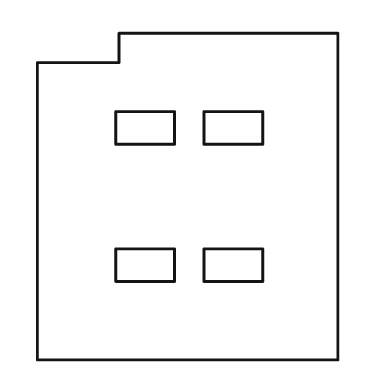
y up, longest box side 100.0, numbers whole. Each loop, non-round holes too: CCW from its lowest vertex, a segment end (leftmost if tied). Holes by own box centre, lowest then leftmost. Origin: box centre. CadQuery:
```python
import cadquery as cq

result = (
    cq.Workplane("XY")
    .moveTo(-46.0, -50.0)
    .lineTo(46.0, -50.0)
    .lineTo(46.0, 50.0)
    .lineTo(-21.0, 50.0)
    .lineTo(-21.0, 41.0)
    .lineTo(-46.0, 41.0)
    .close()
    .moveTo(-22.0, -26.0)
    .lineTo(-4.0, -26.0)
    .lineTo(-4.0, -16.0)
    .lineTo(-22.0, -16.0)
    .close()
    .moveTo(5.0, -26.0)
    .lineTo(23.0, -26.0)
    .lineTo(23.0, -16.0)
    .lineTo(5.0, -16.0)
    .close()
    .moveTo(-22.0, 16.0)
    .lineTo(-4.0, 16.0)
    .lineTo(-4.0, 26.0)
    .lineTo(-22.0, 26.0)
    .close()
    .moveTo(5.0, 16.0)
    .lineTo(23.0, 16.0)
    .lineTo(23.0, 26.0)
    .lineTo(5.0, 26.0)
    .close()
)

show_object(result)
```